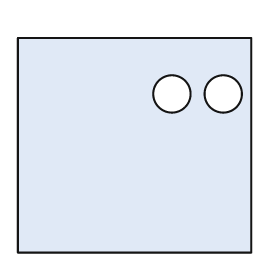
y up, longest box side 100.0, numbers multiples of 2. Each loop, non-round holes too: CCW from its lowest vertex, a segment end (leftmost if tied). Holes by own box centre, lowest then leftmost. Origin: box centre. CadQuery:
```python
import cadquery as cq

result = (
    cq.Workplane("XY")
    .moveTo(-50.0, -46.0)
    .lineTo(50.0, -46.0)
    .lineTo(50.0, 46.0)
    .lineTo(-50.0, 46.0)
    .close()
    .moveTo(16.0, 22.0)
    .circle(8.0)
    .moveTo(38.0, 22.0)
    .circle(8.0)
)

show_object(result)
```